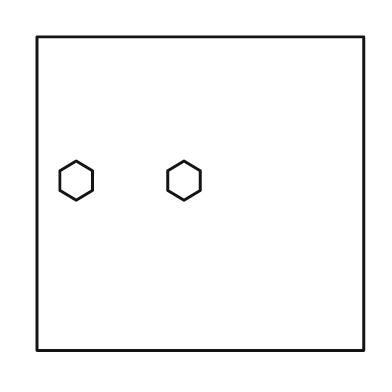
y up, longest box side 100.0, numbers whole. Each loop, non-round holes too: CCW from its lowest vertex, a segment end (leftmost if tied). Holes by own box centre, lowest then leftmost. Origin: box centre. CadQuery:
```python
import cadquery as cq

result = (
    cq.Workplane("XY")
    .moveTo(-50.0, -48.0)
    .lineTo(50.0, -48.0)
    .lineTo(50.0, 48.0)
    .lineTo(-50.0, 48.0)
    .close()
    .moveTo(-38.0, -2.0)
    .lineTo(-33.0, 1.0)
    .lineTo(-33.0, 7.0)
    .lineTo(-38.0, 10.0)
    .lineTo(-43.0, 7.0)
    .lineTo(-43.0, 1.0)
    .close()
    .moveTo(-5.0, -2.0)
    .lineTo(0.0, 1.0)
    .lineTo(0.0, 7.0)
    .lineTo(-5.0, 10.0)
    .lineTo(-10.0, 7.0)
    .lineTo(-10.0, 1.0)
    .close()
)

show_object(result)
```